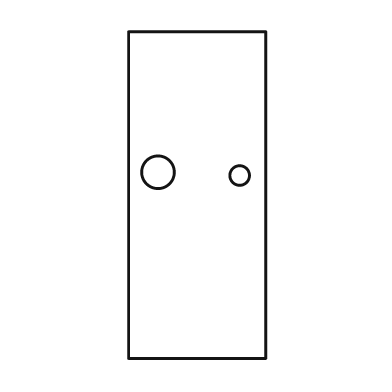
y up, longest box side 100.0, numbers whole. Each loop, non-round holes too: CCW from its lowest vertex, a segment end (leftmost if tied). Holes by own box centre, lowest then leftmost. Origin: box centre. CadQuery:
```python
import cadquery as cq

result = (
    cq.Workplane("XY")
    .moveTo(-21.0, -50.0)
    .lineTo(21.0, -50.0)
    .lineTo(21.0, 50.0)
    .lineTo(-21.0, 50.0)
    .close()
    .moveTo(13.0, 6.0)
    .circle(3.0)
    .moveTo(-12.0, 7.0)
    .circle(5.0)
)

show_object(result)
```